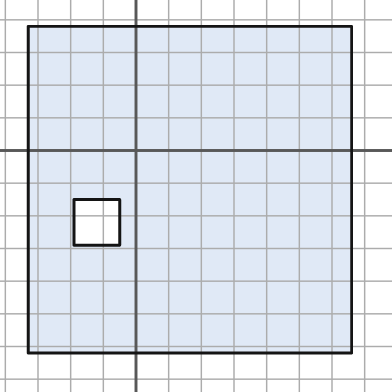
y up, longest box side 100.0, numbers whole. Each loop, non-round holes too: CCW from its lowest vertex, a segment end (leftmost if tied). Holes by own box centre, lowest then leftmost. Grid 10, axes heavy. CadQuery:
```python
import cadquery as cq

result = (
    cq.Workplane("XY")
    .moveTo(-33.0, -62.0)
    .lineTo(66.0, -62.0)
    .lineTo(66.0, 38.0)
    .lineTo(-33.0, 38.0)
    .close()
    .moveTo(-19.0, -29.0)
    .lineTo(-5.0, -29.0)
    .lineTo(-5.0, -15.0)
    .lineTo(-19.0, -15.0)
    .close()
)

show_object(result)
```